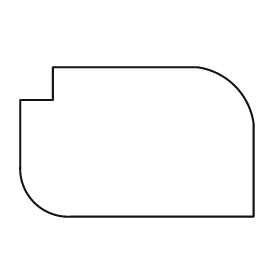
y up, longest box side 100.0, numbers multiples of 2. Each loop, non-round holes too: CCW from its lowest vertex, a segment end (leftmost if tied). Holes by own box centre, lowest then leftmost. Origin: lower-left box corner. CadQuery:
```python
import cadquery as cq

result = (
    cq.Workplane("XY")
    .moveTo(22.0, 0.0)
    .lineTo(100.0, 0.0)
    .lineTo(100.0, 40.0)
    .threePointArc((92.0, 56.0), (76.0, 64.0))
    .lineTo(14.0, 64.0)
    .lineTo(14.0, 50.0)
    .lineTo(0.0, 50.0)
    .lineTo(0.0, 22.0)
    .threePointArc((6.0, 6.0), (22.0, 0.0))
    .close()
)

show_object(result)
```